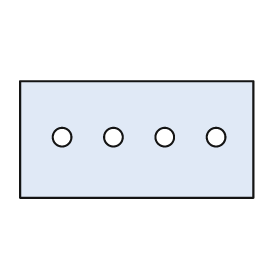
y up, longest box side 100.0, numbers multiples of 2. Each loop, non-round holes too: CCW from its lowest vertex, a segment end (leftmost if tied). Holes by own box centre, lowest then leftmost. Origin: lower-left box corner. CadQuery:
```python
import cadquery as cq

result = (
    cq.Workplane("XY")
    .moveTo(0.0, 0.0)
    .lineTo(100.0, 0.0)
    .lineTo(100.0, 50.0)
    .lineTo(0.0, 50.0)
    .close()
    .moveTo(18.0, 26.0)
    .circle(4.0)
    .moveTo(40.0, 26.0)
    .circle(4.0)
    .moveTo(62.0, 26.0)
    .circle(4.0)
    .moveTo(84.0, 26.0)
    .circle(4.0)
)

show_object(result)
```